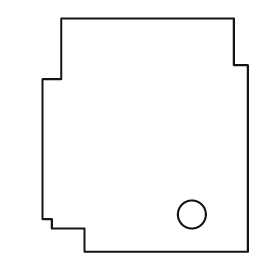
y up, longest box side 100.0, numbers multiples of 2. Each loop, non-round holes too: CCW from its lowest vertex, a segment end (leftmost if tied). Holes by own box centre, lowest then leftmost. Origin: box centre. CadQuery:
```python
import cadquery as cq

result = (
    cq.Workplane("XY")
    .moveTo(-26.0, -50.0)
    .lineTo(44.0, -50.0)
    .lineTo(44.0, 30.0)
    .lineTo(38.0, 30.0)
    .lineTo(38.0, 50.0)
    .lineTo(-36.0, 50.0)
    .lineTo(-36.0, 24.0)
    .lineTo(-44.0, 24.0)
    .lineTo(-44.0, -36.0)
    .lineTo(-40.0, -36.0)
    .lineTo(-40.0, -40.0)
    .lineTo(-26.0, -40.0)
    .close()
    .moveTo(20.0, -34.0)
    .circle(6.0)
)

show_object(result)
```